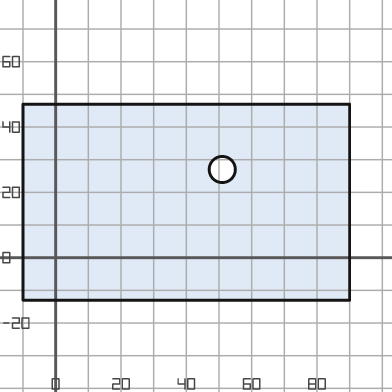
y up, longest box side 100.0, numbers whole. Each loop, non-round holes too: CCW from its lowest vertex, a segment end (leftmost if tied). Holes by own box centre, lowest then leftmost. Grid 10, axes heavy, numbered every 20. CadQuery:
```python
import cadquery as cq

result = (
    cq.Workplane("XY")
    .moveTo(-10.0, -13.0)
    .lineTo(90.0, -13.0)
    .lineTo(90.0, 47.0)
    .lineTo(-10.0, 47.0)
    .close()
    .moveTo(51.0, 27.0)
    .circle(4.0)
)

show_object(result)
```